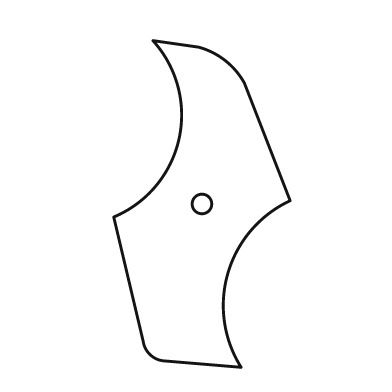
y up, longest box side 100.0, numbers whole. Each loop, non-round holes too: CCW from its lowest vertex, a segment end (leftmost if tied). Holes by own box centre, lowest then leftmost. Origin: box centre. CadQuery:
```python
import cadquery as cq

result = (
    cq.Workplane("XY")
    .moveTo(12.0, -50.0)
    .threePointArc((8.0, -21.0), (27.0, 1.0))
    .lineTo(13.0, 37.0)
    .threePointArc((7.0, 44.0), (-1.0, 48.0))
    .lineTo(-15.0, 50.0)
    .threePointArc((-7.0, 20.0), (-27.0, -4.0))
    .lineTo(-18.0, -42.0)
    .threePointArc((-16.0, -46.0), (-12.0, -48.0))
    .close()
    .moveTo(0.0, 0.0)
    .circle(3.0)
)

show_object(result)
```